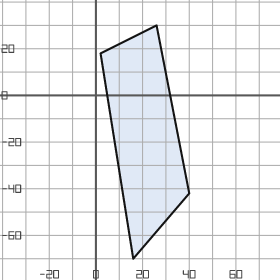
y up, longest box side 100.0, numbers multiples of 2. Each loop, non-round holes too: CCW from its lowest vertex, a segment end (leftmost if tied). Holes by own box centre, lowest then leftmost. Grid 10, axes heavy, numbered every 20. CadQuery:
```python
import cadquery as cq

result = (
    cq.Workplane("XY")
    .moveTo(16.0, -70.0)
    .lineTo(40.0, -42.0)
    .lineTo(26.0, 30.0)
    .lineTo(2.0, 18.0)
    .close()
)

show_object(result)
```